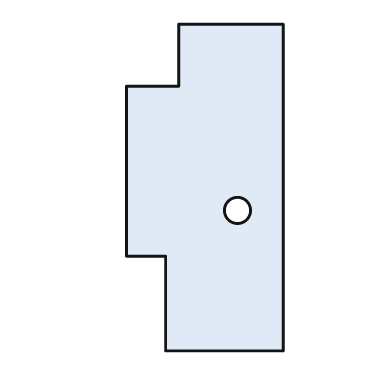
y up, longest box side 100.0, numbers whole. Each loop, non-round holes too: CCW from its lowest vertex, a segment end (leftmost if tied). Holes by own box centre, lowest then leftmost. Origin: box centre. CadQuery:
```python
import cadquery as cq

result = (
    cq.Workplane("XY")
    .moveTo(-12.0, -50.0)
    .lineTo(24.0, -50.0)
    .lineTo(24.0, 50.0)
    .lineTo(-8.0, 50.0)
    .lineTo(-8.0, 31.0)
    .lineTo(-24.0, 31.0)
    .lineTo(-24.0, -21.0)
    .lineTo(-12.0, -21.0)
    .close()
    .moveTo(10.0, -7.0)
    .circle(4.0)
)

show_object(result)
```